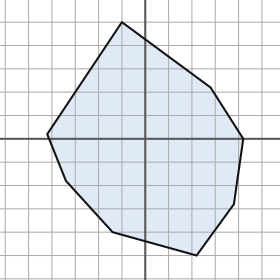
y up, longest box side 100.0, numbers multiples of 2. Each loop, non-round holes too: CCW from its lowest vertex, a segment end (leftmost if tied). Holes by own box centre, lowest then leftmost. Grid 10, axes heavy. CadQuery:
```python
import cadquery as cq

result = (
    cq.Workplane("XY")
    .moveTo(22.0, -50.0)
    .lineTo(38.0, -28.0)
    .lineTo(42.0, 0.0)
    .lineTo(28.0, 22.0)
    .lineTo(-10.0, 50.0)
    .lineTo(-42.0, 2.0)
    .lineTo(-34.0, -18.0)
    .lineTo(-14.0, -40.0)
    .close()
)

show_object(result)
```